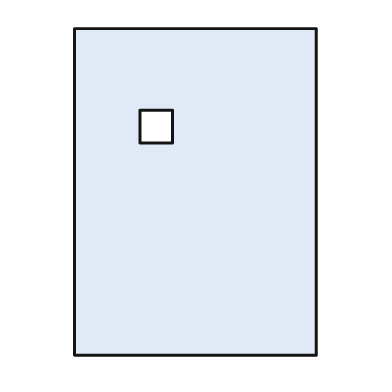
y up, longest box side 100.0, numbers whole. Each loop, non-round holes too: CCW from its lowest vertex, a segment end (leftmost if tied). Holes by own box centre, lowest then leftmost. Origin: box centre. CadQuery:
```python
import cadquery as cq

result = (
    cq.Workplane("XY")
    .moveTo(-37.0, -50.0)
    .lineTo(37.0, -50.0)
    .lineTo(37.0, 50.0)
    .lineTo(-37.0, 50.0)
    .close()
    .moveTo(-17.0, 15.0)
    .lineTo(-7.0, 15.0)
    .lineTo(-7.0, 25.0)
    .lineTo(-17.0, 25.0)
    .close()
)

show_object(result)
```